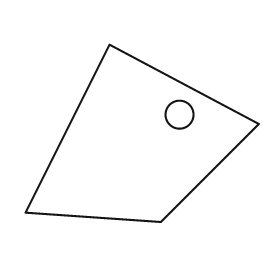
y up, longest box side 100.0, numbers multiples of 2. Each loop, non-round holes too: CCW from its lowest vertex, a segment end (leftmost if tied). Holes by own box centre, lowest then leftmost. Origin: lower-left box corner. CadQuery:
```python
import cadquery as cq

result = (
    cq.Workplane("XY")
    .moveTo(58.0, 0.0)
    .lineTo(100.0, 42.0)
    .lineTo(36.0, 76.0)
    .lineTo(0.0, 4.0)
    .close()
    .moveTo(66.0, 46.0)
    .circle(6.0)
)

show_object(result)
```